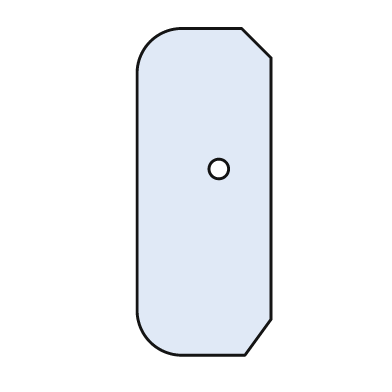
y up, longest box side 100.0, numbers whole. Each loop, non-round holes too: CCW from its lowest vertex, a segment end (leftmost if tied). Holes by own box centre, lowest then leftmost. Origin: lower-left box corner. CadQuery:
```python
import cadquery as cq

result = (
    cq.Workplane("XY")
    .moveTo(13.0, 0.0)
    .lineTo(33.0, 0.0)
    .lineTo(41.0, 11.0)
    .lineTo(41.0, 91.0)
    .lineTo(32.0, 100.0)
    .lineTo(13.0, 100.0)
    .threePointArc((4.0, 96.0), (0.0, 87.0))
    .lineTo(0.0, 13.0)
    .threePointArc((4.0, 4.0), (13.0, 0.0))
    .close()
    .moveTo(25.0, 57.0)
    .circle(3.0)
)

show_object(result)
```